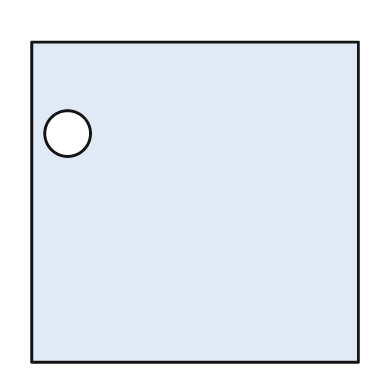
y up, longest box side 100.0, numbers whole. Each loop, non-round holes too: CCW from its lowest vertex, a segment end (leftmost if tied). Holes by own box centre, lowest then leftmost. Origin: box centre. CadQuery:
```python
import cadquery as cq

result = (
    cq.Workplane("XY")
    .moveTo(-50.0, -49.0)
    .lineTo(50.0, -49.0)
    .lineTo(50.0, 49.0)
    .lineTo(-50.0, 49.0)
    .close()
    .moveTo(-39.0, 21.0)
    .circle(7.0)
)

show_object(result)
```